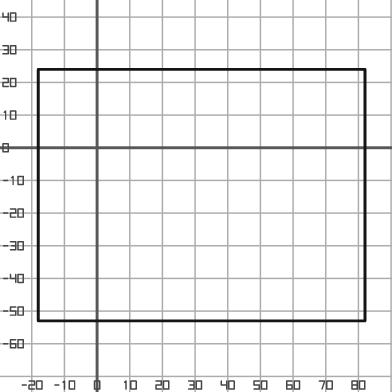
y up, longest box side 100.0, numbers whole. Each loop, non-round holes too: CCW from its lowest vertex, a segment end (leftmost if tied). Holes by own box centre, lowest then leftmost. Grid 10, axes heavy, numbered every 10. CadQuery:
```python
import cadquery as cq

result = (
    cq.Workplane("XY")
    .moveTo(-18.0, -53.0)
    .lineTo(82.0, -53.0)
    .lineTo(82.0, 24.0)
    .lineTo(-18.0, 24.0)
    .close()
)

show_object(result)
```